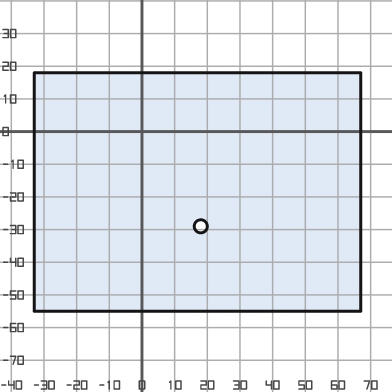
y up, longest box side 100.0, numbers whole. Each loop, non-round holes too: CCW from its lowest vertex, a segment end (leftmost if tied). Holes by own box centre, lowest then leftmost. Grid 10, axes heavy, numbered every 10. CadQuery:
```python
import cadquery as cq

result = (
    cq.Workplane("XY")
    .moveTo(-33.0, -55.0)
    .lineTo(67.0, -55.0)
    .lineTo(67.0, 18.0)
    .lineTo(-33.0, 18.0)
    .close()
    .moveTo(18.0, -29.0)
    .circle(2.0)
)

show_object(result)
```